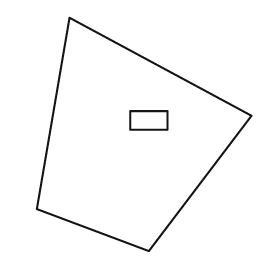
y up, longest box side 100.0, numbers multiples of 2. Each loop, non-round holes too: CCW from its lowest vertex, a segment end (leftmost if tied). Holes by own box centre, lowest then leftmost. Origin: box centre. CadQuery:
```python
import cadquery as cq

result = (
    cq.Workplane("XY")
    .moveTo(2.0, -50.0)
    .lineTo(46.0, 8.0)
    .lineTo(-32.0, 50.0)
    .lineTo(-46.0, -32.0)
    .close()
    .moveTo(-6.0, 2.0)
    .lineTo(10.0, 2.0)
    .lineTo(10.0, 10.0)
    .lineTo(-6.0, 10.0)
    .close()
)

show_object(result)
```